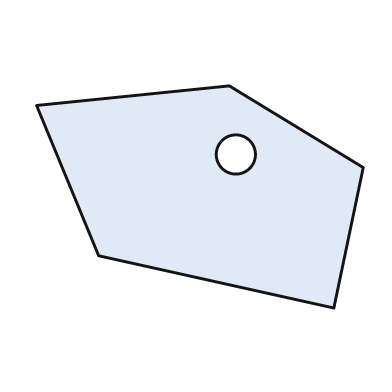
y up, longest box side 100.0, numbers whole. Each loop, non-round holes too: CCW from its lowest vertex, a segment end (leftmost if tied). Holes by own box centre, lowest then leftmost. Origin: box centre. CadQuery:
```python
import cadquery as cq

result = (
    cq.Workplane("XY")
    .moveTo(41.0, -34.0)
    .lineTo(50.0, 9.0)
    .lineTo(9.0, 34.0)
    .lineTo(-50.0, 28.0)
    .lineTo(-31.0, -18.0)
    .close()
    .moveTo(11.0, 13.0)
    .circle(6.0)
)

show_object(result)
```